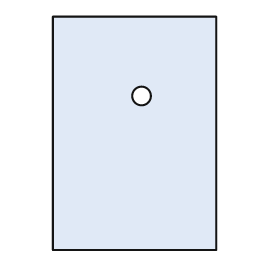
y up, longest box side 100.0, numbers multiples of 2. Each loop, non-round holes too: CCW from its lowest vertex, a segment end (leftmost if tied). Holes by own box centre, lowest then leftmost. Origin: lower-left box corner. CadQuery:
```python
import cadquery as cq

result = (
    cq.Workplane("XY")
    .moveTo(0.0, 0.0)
    .lineTo(70.0, 0.0)
    .lineTo(70.0, 100.0)
    .lineTo(0.0, 100.0)
    .close()
    .moveTo(38.0, 66.0)
    .circle(4.0)
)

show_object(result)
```